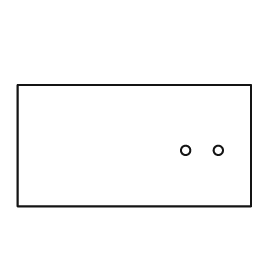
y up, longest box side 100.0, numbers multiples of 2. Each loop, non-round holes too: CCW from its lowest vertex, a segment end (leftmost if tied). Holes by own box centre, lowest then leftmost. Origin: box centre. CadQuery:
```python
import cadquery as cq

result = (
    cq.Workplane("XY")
    .moveTo(-50.0, -26.0)
    .lineTo(50.0, -26.0)
    .lineTo(50.0, 26.0)
    .lineTo(-50.0, 26.0)
    .close()
    .moveTo(22.0, -2.0)
    .circle(2.0)
    .moveTo(36.0, -2.0)
    .circle(2.0)
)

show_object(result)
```